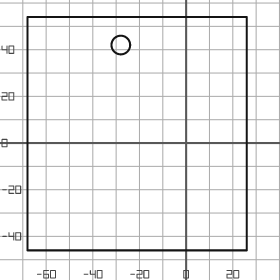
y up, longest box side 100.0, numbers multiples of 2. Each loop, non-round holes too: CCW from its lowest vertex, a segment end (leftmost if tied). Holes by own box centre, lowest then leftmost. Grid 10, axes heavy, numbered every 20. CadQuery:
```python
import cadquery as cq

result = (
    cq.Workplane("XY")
    .moveTo(-68.0, -46.0)
    .lineTo(26.0, -46.0)
    .lineTo(26.0, 54.0)
    .lineTo(-68.0, 54.0)
    .close()
    .moveTo(-28.0, 42.0)
    .circle(4.0)
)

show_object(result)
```